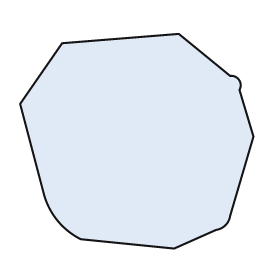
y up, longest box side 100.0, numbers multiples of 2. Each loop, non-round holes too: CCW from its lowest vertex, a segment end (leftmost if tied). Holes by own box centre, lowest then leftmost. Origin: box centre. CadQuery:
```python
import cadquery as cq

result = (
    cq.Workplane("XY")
    .moveTo(16.0, -46.0)
    .lineTo(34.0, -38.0)
    .threePointArc((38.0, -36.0), (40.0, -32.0))
    .lineTo(50.0, 2.0)
    .lineTo(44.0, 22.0)
    .threePointArc((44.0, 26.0), (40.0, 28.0))
    .lineTo(18.0, 46.0)
    .lineTo(-32.0, 42.0)
    .lineTo(-50.0, 16.0)
    .lineTo(-40.0, -22.0)
    .threePointArc((-34.0, -34.0), (-24.0, -42.0))
    .close()
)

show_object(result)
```